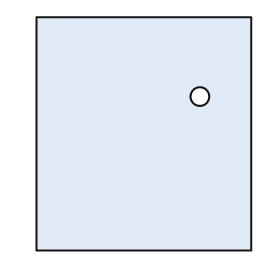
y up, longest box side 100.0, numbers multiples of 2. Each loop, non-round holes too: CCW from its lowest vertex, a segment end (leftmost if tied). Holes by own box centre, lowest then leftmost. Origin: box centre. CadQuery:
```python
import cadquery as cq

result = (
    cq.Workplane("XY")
    .moveTo(-46.0, -50.0)
    .lineTo(46.0, -50.0)
    .lineTo(46.0, 50.0)
    .lineTo(-46.0, 50.0)
    .close()
    .moveTo(24.0, 16.0)
    .circle(4.0)
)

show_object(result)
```